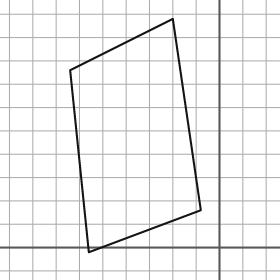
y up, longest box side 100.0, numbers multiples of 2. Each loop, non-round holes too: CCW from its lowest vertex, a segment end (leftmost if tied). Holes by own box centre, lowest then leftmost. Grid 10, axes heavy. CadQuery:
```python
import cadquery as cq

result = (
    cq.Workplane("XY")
    .moveTo(-56.0, -2.0)
    .lineTo(-8.0, 16.0)
    .lineTo(-20.0, 98.0)
    .lineTo(-64.0, 76.0)
    .close()
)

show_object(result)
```